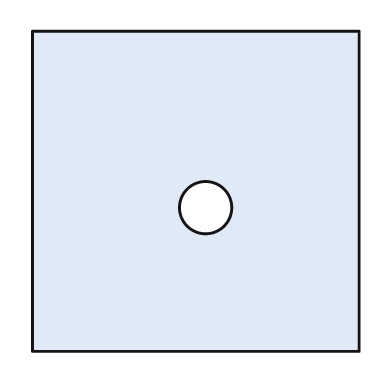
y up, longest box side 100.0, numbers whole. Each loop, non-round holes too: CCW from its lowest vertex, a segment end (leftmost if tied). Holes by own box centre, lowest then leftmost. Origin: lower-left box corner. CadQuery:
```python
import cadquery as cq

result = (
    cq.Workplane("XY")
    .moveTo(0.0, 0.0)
    .lineTo(100.0, 0.0)
    .lineTo(100.0, 98.0)
    .lineTo(0.0, 98.0)
    .close()
    .moveTo(53.0, 44.0)
    .circle(8.0)
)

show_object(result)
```